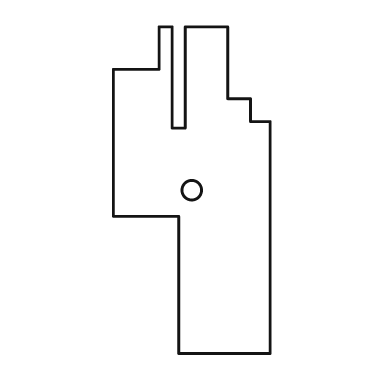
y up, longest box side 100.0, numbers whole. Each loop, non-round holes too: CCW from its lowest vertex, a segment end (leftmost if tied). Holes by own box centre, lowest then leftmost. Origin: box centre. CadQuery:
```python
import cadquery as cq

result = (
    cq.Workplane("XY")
    .moveTo(-4.0, -50.0)
    .lineTo(24.0, -50.0)
    .lineTo(24.0, 21.0)
    .lineTo(18.0, 21.0)
    .lineTo(18.0, 28.0)
    .lineTo(11.0, 28.0)
    .lineTo(11.0, 50.0)
    .lineTo(-2.0, 50.0)
    .lineTo(-2.0, 19.0)
    .lineTo(-6.0, 19.0)
    .lineTo(-6.0, 50.0)
    .lineTo(-10.0, 50.0)
    .lineTo(-10.0, 37.0)
    .lineTo(-24.0, 37.0)
    .lineTo(-24.0, -8.0)
    .lineTo(-4.0, -8.0)
    .close()
    .moveTo(0.0, 0.0)
    .circle(3.0)
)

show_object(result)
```